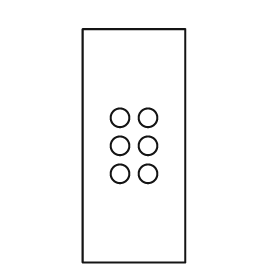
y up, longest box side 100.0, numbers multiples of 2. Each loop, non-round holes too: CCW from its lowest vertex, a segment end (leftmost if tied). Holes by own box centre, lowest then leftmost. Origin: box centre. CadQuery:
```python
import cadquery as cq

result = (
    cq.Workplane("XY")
    .moveTo(-22.0, -50.0)
    .lineTo(22.0, -50.0)
    .lineTo(22.0, 50.0)
    .lineTo(-22.0, 50.0)
    .close()
    .moveTo(-6.0, -12.0)
    .circle(4.0)
    .moveTo(6.0, -12.0)
    .circle(4.0)
    .moveTo(-6.0, 0.0)
    .circle(4.0)
    .moveTo(6.0, 0.0)
    .circle(4.0)
    .moveTo(-6.0, 12.0)
    .circle(4.0)
    .moveTo(6.0, 12.0)
    .circle(4.0)
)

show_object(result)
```